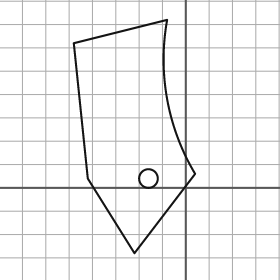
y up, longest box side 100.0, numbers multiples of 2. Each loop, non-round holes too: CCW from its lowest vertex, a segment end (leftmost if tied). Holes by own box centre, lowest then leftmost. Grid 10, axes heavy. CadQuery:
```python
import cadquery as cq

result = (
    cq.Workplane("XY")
    .moveTo(-22.0, -28.0)
    .lineTo(4.0, 6.0)
    .threePointArc((-8.0, 38.0), (-8.0, 72.0))
    .lineTo(-48.0, 62.0)
    .lineTo(-42.0, 4.0)
    .close()
    .moveTo(-16.0, 4.0)
    .circle(4.0)
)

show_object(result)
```